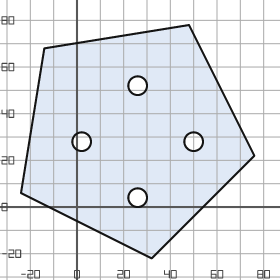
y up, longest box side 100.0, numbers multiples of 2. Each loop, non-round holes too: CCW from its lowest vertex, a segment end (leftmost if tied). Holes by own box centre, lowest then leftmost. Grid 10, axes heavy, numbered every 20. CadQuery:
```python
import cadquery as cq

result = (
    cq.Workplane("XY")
    .moveTo(32.0, -22.0)
    .lineTo(76.0, 22.0)
    .lineTo(48.0, 78.0)
    .lineTo(-14.0, 68.0)
    .lineTo(-24.0, 6.0)
    .close()
    .moveTo(26.0, 4.0)
    .circle(4.0)
    .moveTo(2.0, 28.0)
    .circle(4.0)
    .moveTo(50.0, 28.0)
    .circle(4.0)
    .moveTo(26.0, 52.0)
    .circle(4.0)
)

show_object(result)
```